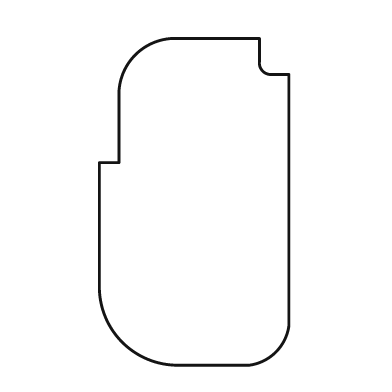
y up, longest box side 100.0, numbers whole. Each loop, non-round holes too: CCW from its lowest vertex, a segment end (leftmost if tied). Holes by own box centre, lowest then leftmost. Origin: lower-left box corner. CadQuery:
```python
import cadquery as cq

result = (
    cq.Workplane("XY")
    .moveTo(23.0, 0.0)
    .lineTo(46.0, 0.0)
    .threePointArc((54.0, 4.0), (58.0, 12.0))
    .lineTo(58.0, 89.0)
    .lineTo(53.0, 89.0)
    .threePointArc((50.0, 90.0), (49.0, 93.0))
    .lineTo(49.0, 100.0)
    .lineTo(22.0, 100.0)
    .threePointArc((11.0, 95.0), (6.0, 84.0))
    .lineTo(6.0, 62.0)
    .lineTo(0.0, 62.0)
    .lineTo(0.0, 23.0)
    .threePointArc((7.0, 7.0), (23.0, 0.0))
    .close()
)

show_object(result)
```